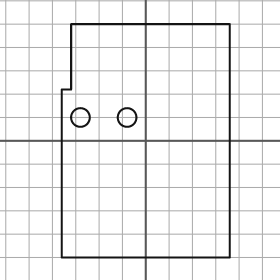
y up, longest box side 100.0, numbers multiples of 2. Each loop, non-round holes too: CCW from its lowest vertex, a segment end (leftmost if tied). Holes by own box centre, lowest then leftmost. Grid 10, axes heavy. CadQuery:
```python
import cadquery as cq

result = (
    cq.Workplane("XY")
    .moveTo(-36.0, -50.0)
    .lineTo(36.0, -50.0)
    .lineTo(36.0, 50.0)
    .lineTo(-32.0, 50.0)
    .lineTo(-32.0, 22.0)
    .lineTo(-36.0, 22.0)
    .close()
    .moveTo(-28.0, 10.0)
    .circle(4.0)
    .moveTo(-8.0, 10.0)
    .circle(4.0)
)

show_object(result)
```